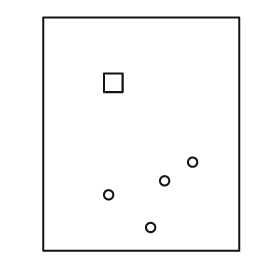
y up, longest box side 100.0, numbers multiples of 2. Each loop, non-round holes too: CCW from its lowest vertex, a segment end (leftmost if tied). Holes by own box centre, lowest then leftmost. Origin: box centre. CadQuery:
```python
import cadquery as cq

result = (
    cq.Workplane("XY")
    .moveTo(-42.0, -50.0)
    .lineTo(42.0, -50.0)
    .lineTo(42.0, 50.0)
    .lineTo(-42.0, 50.0)
    .close()
    .moveTo(4.0, -40.0)
    .circle(2.0)
    .moveTo(-14.0, -26.0)
    .circle(2.0)
    .moveTo(10.0, -20.0)
    .circle(2.0)
    .moveTo(22.0, -12.0)
    .circle(2.0)
    .moveTo(-16.0, 18.0)
    .lineTo(-8.0, 18.0)
    .lineTo(-8.0, 26.0)
    .lineTo(-16.0, 26.0)
    .close()
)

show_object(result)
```